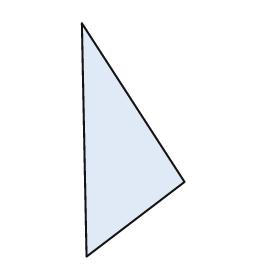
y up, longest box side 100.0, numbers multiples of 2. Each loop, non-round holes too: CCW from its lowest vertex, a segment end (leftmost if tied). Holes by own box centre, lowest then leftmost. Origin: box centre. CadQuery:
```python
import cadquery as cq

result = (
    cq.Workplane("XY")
    .moveTo(-20.0, -50.0)
    .lineTo(22.0, -18.0)
    .lineTo(-22.0, 50.0)
    .close()
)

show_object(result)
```